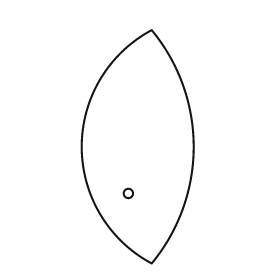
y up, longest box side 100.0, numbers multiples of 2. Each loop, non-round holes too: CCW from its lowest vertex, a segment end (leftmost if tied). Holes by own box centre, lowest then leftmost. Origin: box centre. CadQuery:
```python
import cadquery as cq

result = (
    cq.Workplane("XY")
    .moveTo(6.0, -50.0)
    .threePointArc((24.0, 0.0), (6.0, 50.0))
    .threePointArc((-24.0, 0.0), (6.0, -50.0))
    .close()
    .moveTo(-4.0, -20.0)
    .circle(2.0)
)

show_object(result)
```